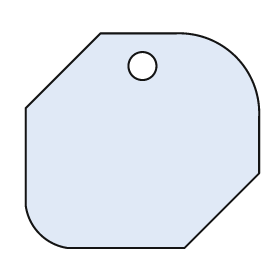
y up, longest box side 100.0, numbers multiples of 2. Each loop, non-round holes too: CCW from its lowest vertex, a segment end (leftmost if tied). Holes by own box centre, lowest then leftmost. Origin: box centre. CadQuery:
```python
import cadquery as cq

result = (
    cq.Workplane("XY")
    .moveTo(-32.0, -46.0)
    .lineTo(18.0, -46.0)
    .lineTo(50.0, -14.0)
    .lineTo(50.0, 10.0)
    .threePointArc((40.0, 36.0), (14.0, 46.0))
    .lineTo(-18.0, 46.0)
    .lineTo(-50.0, 14.0)
    .lineTo(-50.0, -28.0)
    .threePointArc((-44.0, -40.0), (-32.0, -46.0))
    .close()
    .moveTo(0.0, 32.0)
    .circle(6.0)
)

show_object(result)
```